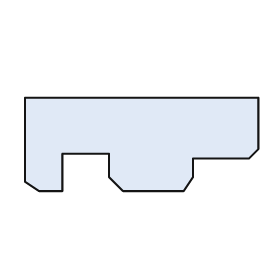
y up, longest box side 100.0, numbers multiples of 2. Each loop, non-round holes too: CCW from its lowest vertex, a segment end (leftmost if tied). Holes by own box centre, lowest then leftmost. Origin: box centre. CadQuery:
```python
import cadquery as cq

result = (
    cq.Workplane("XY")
    .moveTo(-44.0, -20.0)
    .lineTo(-34.0, -20.0)
    .lineTo(-34.0, -4.0)
    .lineTo(-14.0, -4.0)
    .lineTo(-14.0, -14.0)
    .lineTo(-8.0, -20.0)
    .lineTo(18.0, -20.0)
    .lineTo(22.0, -14.0)
    .lineTo(22.0, -6.0)
    .lineTo(46.0, -6.0)
    .lineTo(50.0, -2.0)
    .lineTo(50.0, 20.0)
    .lineTo(-50.0, 20.0)
    .lineTo(-50.0, -16.0)
    .close()
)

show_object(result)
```